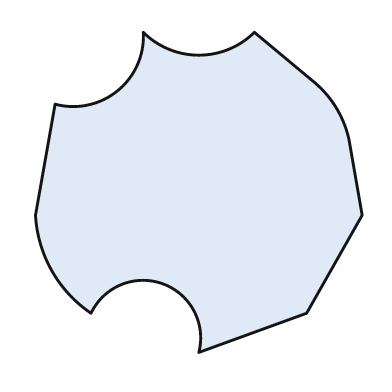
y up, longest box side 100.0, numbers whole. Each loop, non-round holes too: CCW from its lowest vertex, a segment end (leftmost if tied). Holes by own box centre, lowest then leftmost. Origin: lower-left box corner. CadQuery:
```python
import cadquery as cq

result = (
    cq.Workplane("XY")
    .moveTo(50.0, 0.0)
    .lineTo(83.0, 12.0)
    .lineTo(100.0, 42.0)
    .lineTo(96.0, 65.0)
    .threePointArc((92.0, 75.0), (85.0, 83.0))
    .lineTo(67.0, 98.0)
    .threePointArc((50.0, 91.0), (33.0, 98.0))
    .threePointArc((25.0, 80.0), (6.0, 76.0))
    .lineTo(0.0, 42.0)
    .threePointArc((5.0, 25.0), (17.0, 12.0))
    .threePointArc((39.0, 21.0), (50.0, 0.0))
    .close()
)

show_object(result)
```